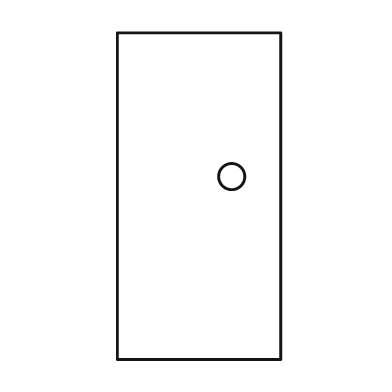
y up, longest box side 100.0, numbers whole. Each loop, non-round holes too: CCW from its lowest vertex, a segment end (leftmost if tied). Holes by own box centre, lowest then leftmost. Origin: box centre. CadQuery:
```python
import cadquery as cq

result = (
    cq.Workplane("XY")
    .moveTo(-25.0, -50.0)
    .lineTo(25.0, -50.0)
    .lineTo(25.0, 50.0)
    .lineTo(-25.0, 50.0)
    .close()
    .moveTo(10.0, 6.0)
    .circle(4.0)
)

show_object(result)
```